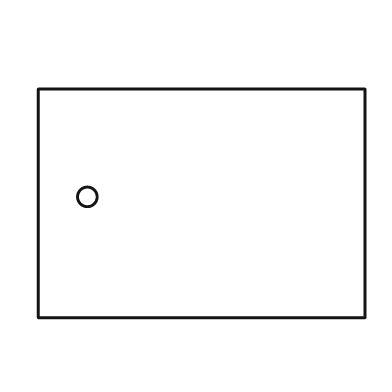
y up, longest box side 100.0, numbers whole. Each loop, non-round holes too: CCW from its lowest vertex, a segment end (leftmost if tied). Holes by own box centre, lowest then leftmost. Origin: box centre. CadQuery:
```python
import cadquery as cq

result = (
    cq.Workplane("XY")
    .moveTo(-50.0, -35.0)
    .lineTo(50.0, -35.0)
    .lineTo(50.0, 35.0)
    .lineTo(-50.0, 35.0)
    .close()
    .moveTo(-35.0, 2.0)
    .circle(3.0)
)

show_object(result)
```